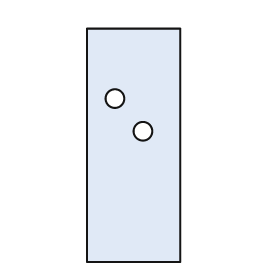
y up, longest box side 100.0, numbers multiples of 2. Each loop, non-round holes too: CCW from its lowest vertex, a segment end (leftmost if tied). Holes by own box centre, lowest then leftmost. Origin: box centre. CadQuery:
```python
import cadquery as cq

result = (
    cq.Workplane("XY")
    .moveTo(-20.0, -50.0)
    .lineTo(20.0, -50.0)
    .lineTo(20.0, 50.0)
    .lineTo(-20.0, 50.0)
    .close()
    .moveTo(4.0, 6.0)
    .circle(4.0)
    .moveTo(-8.0, 20.0)
    .circle(4.0)
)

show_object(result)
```